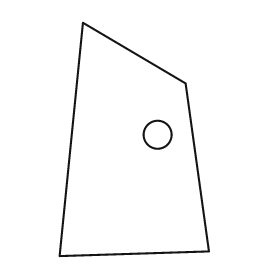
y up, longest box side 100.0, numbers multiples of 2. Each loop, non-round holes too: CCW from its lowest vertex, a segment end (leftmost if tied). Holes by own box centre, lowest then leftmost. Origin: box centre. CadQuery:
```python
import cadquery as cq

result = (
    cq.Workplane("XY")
    .moveTo(-32.0, -50.0)
    .lineTo(32.0, -48.0)
    .lineTo(22.0, 24.0)
    .lineTo(-22.0, 50.0)
    .close()
    .moveTo(10.0, 2.0)
    .circle(6.0)
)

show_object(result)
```